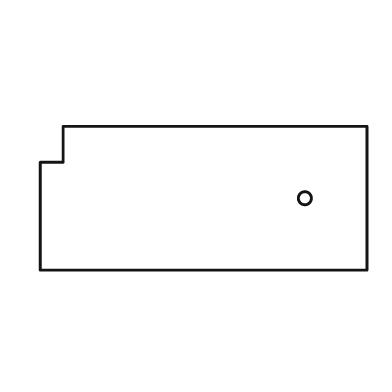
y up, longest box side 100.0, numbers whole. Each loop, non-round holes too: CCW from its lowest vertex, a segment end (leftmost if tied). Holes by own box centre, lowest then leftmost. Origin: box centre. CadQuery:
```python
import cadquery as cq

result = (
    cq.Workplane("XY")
    .moveTo(-50.0, -22.0)
    .lineTo(50.0, -22.0)
    .lineTo(50.0, 22.0)
    .lineTo(-43.0, 22.0)
    .lineTo(-43.0, 11.0)
    .lineTo(-50.0, 11.0)
    .close()
    .moveTo(31.0, 0.0)
    .circle(2.0)
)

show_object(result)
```